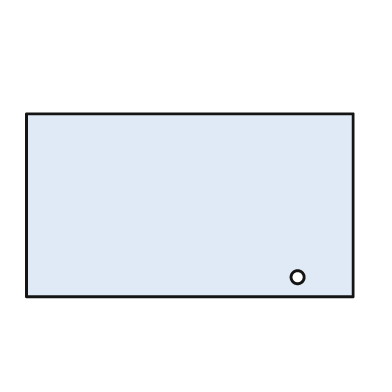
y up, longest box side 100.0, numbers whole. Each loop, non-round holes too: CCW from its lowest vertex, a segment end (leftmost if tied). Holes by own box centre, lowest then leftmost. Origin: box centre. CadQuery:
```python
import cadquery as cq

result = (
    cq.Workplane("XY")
    .moveTo(-50.0, -28.0)
    .lineTo(50.0, -28.0)
    .lineTo(50.0, 28.0)
    .lineTo(-50.0, 28.0)
    .close()
    .moveTo(33.0, -22.0)
    .circle(2.0)
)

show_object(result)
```